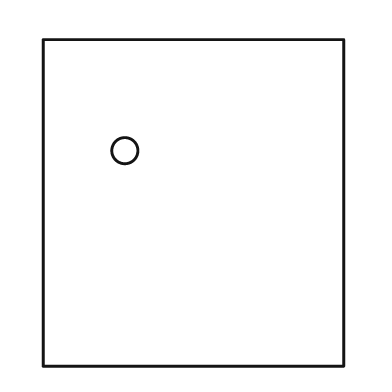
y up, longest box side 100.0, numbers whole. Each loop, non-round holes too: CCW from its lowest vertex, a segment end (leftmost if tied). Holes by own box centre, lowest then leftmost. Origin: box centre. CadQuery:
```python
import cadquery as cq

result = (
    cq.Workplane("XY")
    .moveTo(-46.0, -50.0)
    .lineTo(46.0, -50.0)
    .lineTo(46.0, 50.0)
    .lineTo(-46.0, 50.0)
    .close()
    .moveTo(-21.0, 16.0)
    .circle(4.0)
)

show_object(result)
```